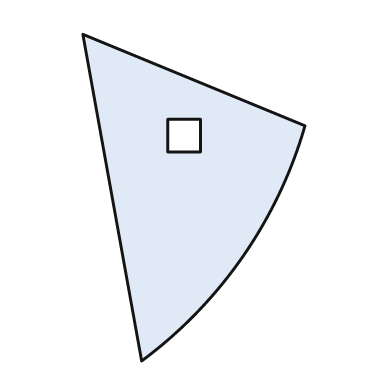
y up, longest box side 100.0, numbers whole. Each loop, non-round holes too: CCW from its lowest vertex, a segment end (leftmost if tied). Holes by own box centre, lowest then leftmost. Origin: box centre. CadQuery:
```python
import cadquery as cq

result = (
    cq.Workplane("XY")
    .moveTo(-16.0, -50.0)
    .threePointArc((15.0, -18.0), (34.0, 22.0))
    .lineTo(-34.0, 50.0)
    .close()
    .moveTo(-8.0, 14.0)
    .lineTo(2.0, 14.0)
    .lineTo(2.0, 24.0)
    .lineTo(-8.0, 24.0)
    .close()
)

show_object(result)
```